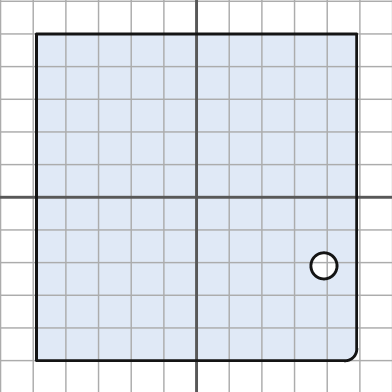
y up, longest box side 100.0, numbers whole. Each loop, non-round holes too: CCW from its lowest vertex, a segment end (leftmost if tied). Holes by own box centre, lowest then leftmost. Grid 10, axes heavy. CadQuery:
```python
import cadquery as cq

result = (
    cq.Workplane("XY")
    .moveTo(-49.0, -50.0)
    .lineTo(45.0, -50.0)
    .threePointArc((48.0, -49.0), (49.0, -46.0))
    .lineTo(49.0, 50.0)
    .lineTo(-49.0, 50.0)
    .close()
    .moveTo(39.0, -21.0)
    .circle(4.0)
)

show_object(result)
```